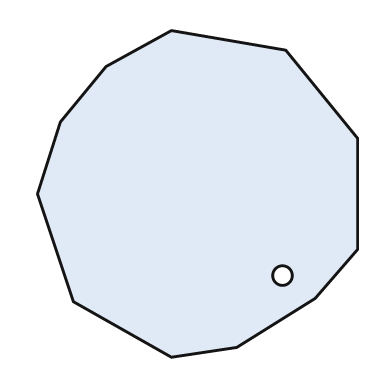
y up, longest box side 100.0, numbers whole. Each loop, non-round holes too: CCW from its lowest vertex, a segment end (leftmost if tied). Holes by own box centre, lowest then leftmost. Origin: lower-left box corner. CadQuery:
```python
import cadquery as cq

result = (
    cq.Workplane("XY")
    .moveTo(41.0, 0.0)
    .lineTo(61.0, 3.0)
    .lineTo(85.0, 18.0)
    .lineTo(98.0, 33.0)
    .lineTo(98.0, 67.0)
    .lineTo(76.0, 94.0)
    .lineTo(41.0, 100.0)
    .lineTo(21.0, 89.0)
    .lineTo(7.0, 72.0)
    .lineTo(0.0, 50.0)
    .lineTo(11.0, 17.0)
    .close()
    .moveTo(75.0, 25.0)
    .circle(3.0)
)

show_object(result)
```